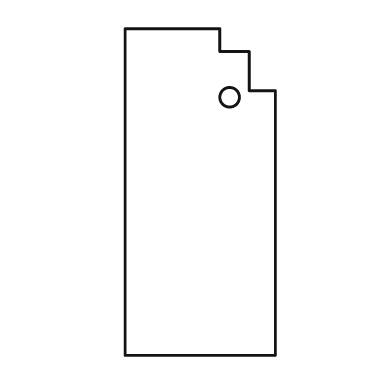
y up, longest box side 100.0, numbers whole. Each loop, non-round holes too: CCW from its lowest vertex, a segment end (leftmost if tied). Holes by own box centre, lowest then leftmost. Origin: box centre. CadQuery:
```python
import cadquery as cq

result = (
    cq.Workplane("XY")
    .moveTo(-23.0, -50.0)
    .lineTo(23.0, -50.0)
    .lineTo(23.0, 31.0)
    .lineTo(15.0, 31.0)
    .lineTo(15.0, 43.0)
    .lineTo(6.0, 43.0)
    .lineTo(6.0, 50.0)
    .lineTo(-23.0, 50.0)
    .close()
    .moveTo(9.0, 29.0)
    .circle(3.0)
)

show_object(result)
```